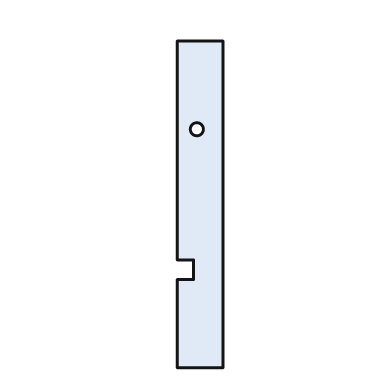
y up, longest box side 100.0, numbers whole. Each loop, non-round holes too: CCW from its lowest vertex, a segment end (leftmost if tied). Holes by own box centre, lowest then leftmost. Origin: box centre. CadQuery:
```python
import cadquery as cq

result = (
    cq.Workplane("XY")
    .moveTo(-7.0, -50.0)
    .lineTo(7.0, -50.0)
    .lineTo(7.0, 50.0)
    .lineTo(-7.0, 50.0)
    .lineTo(-7.0, -17.0)
    .lineTo(-2.0, -17.0)
    .lineTo(-2.0, -23.0)
    .lineTo(-7.0, -23.0)
    .close()
    .moveTo(-1.0, 23.0)
    .circle(2.0)
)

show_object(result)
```